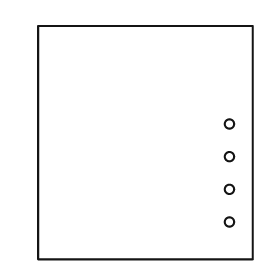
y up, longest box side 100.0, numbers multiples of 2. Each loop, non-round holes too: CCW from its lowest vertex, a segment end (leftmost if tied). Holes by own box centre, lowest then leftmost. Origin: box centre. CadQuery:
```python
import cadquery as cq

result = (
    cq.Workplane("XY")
    .moveTo(-46.0, -50.0)
    .lineTo(46.0, -50.0)
    .lineTo(46.0, 50.0)
    .lineTo(-46.0, 50.0)
    .close()
    .moveTo(36.0, -34.0)
    .circle(2.0)
    .moveTo(36.0, -20.0)
    .circle(2.0)
    .moveTo(36.0, -6.0)
    .circle(2.0)
    .moveTo(36.0, 8.0)
    .circle(2.0)
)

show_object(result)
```